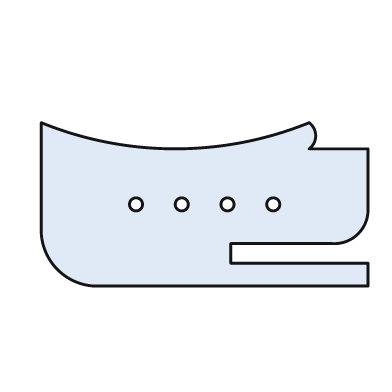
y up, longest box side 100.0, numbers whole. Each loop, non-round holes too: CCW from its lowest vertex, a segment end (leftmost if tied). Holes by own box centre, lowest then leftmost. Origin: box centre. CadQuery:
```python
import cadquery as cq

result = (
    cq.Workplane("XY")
    .moveTo(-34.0, -25.0)
    .lineTo(50.0, -25.0)
    .lineTo(50.0, -18.0)
    .lineTo(8.0, -18.0)
    .lineTo(8.0, -12.0)
    .lineTo(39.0, -12.0)
    .threePointArc((47.0, -9.0), (50.0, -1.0))
    .lineTo(50.0, 17.0)
    .lineTo(32.0, 17.0)
    .threePointArc((34.0, 21.0), (32.0, 25.0))
    .threePointArc((-9.0, 17.0), (-50.0, 25.0))
    .lineTo(-50.0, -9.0)
    .threePointArc((-45.0, -20.0), (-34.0, -25.0))
    .close()
    .moveTo(-21.0, 0.0)
    .circle(2.0)
    .moveTo(-7.0, 0.0)
    .circle(2.0)
    .moveTo(7.0, 0.0)
    .circle(2.0)
    .moveTo(21.0, 0.0)
    .circle(2.0)
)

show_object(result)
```